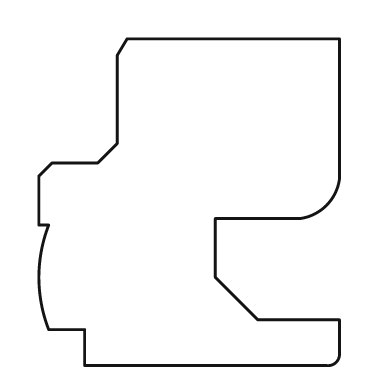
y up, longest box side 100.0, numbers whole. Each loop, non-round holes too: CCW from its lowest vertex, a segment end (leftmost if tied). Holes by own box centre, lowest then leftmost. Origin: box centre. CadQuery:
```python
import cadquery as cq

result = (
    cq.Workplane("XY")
    .moveTo(-32.0, -50.0)
    .lineTo(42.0, -50.0)
    .threePointArc((45.0, -49.0), (46.0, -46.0))
    .lineTo(46.0, -36.0)
    .lineTo(21.0, -36.0)
    .lineTo(8.0, -23.0)
    .lineTo(8.0, -5.0)
    .lineTo(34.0, -5.0)
    .threePointArc((42.0, -1.0), (46.0, 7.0))
    .lineTo(46.0, 50.0)
    .lineTo(-19.0, 50.0)
    .lineTo(-22.0, 45.0)
    .lineTo(-22.0, 18.0)
    .lineTo(-28.0, 12.0)
    .lineTo(-42.0, 12.0)
    .lineTo(-46.0, 8.0)
    .lineTo(-46.0, -7.0)
    .lineTo(-43.0, -7.0)
    .threePointArc((-46.0, -23.0), (-43.0, -39.0))
    .lineTo(-32.0, -39.0)
    .close()
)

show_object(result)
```